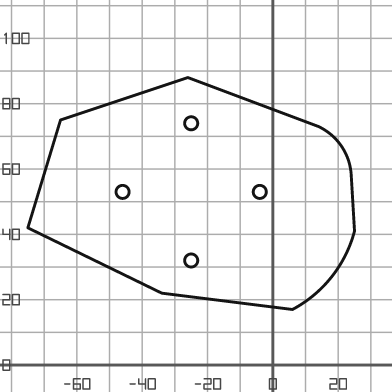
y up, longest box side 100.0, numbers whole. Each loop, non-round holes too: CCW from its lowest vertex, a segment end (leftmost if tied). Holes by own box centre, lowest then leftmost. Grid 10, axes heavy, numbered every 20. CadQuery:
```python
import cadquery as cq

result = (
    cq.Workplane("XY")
    .moveTo(6.0, 17.0)
    .threePointArc((18.0, 27.0), (25.0, 41.0))
    .lineTo(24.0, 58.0)
    .threePointArc((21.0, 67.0), (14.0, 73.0))
    .lineTo(-26.0, 88.0)
    .lineTo(-65.0, 75.0)
    .lineTo(-75.0, 42.0)
    .lineTo(-34.0, 22.0)
    .close()
    .moveTo(-25.0, 32.0)
    .circle(2.0)
    .moveTo(-46.0, 53.0)
    .circle(2.0)
    .moveTo(-4.0, 53.0)
    .circle(2.0)
    .moveTo(-25.0, 74.0)
    .circle(2.0)
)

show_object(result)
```